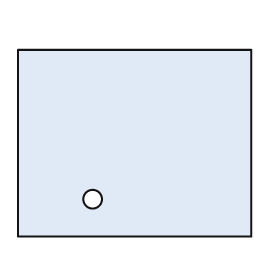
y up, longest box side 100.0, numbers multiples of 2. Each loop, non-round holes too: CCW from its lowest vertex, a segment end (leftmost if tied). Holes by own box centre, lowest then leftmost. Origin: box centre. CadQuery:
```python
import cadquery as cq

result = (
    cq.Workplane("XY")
    .moveTo(-50.0, -40.0)
    .lineTo(50.0, -40.0)
    .lineTo(50.0, 40.0)
    .lineTo(-50.0, 40.0)
    .close()
    .moveTo(-18.0, -24.0)
    .circle(4.0)
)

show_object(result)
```